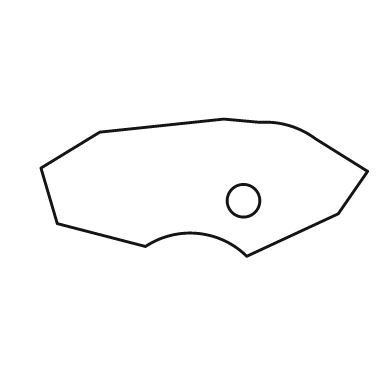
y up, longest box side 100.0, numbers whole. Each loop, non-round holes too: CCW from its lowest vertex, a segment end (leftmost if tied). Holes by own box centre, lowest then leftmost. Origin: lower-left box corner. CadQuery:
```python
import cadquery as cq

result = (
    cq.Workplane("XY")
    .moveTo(63.0, 0.0)
    .lineTo(91.0, 13.0)
    .lineTo(100.0, 26.0)
    .lineTo(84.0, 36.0)
    .threePointArc((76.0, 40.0), (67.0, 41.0))
    .lineTo(56.0, 42.0)
    .lineTo(18.0, 38.0)
    .lineTo(0.0, 27.0)
    .lineTo(5.0, 10.0)
    .lineTo(32.0, 3.0)
    .threePointArc((48.0, 7.0), (63.0, 0.0))
    .close()
    .moveTo(62.0, 17.0)
    .circle(5.0)
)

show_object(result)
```